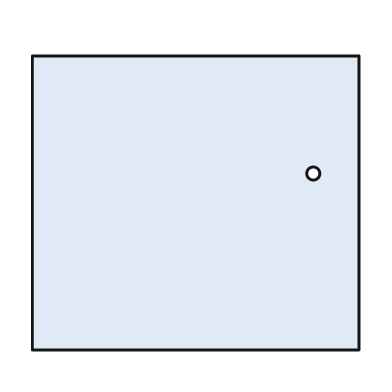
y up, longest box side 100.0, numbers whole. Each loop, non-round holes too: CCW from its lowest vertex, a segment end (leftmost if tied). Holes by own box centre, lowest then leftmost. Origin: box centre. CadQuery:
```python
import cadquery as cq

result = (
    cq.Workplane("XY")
    .moveTo(-50.0, -45.0)
    .lineTo(50.0, -45.0)
    .lineTo(50.0, 45.0)
    .lineTo(-50.0, 45.0)
    .close()
    .moveTo(36.0, 9.0)
    .circle(2.0)
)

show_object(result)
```